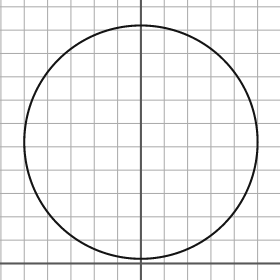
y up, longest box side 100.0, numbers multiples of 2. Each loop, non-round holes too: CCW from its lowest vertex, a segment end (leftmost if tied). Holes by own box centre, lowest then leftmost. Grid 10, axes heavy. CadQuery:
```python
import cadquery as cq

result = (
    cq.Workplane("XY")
    .moveTo(0.0, 52.0)
    .circle(50.0)
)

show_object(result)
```